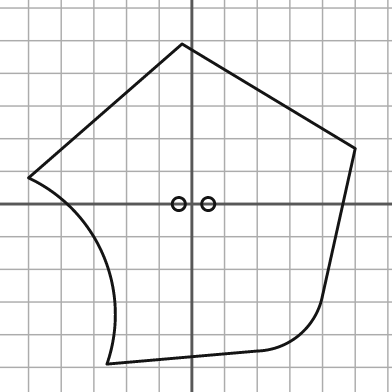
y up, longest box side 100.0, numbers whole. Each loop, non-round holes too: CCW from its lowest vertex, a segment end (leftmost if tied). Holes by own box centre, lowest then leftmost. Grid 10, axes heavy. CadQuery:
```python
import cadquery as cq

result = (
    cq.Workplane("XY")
    .moveTo(-26.0, -49.0)
    .lineTo(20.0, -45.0)
    .threePointArc((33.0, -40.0), (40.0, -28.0))
    .lineTo(50.0, 17.0)
    .lineTo(-3.0, 49.0)
    .lineTo(-50.0, 8.0)
    .threePointArc((-27.0, -16.0), (-26.0, -49.0))
    .close()
    .moveTo(-4.0, 0.0)
    .circle(2.0)
    .moveTo(5.0, 0.0)
    .circle(2.0)
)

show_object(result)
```